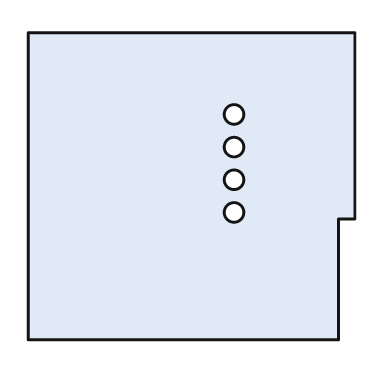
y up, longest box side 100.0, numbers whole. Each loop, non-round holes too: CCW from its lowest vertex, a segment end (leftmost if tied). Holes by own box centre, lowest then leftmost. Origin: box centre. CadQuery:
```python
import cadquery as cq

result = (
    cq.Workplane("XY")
    .moveTo(-50.0, -47.0)
    .lineTo(45.0, -47.0)
    .lineTo(45.0, -10.0)
    .lineTo(50.0, -10.0)
    .lineTo(50.0, 47.0)
    .lineTo(-50.0, 47.0)
    .close()
    .moveTo(13.0, -8.0)
    .circle(3.0)
    .moveTo(13.0, 2.0)
    .circle(3.0)
    .moveTo(13.0, 12.0)
    .circle(3.0)
    .moveTo(13.0, 22.0)
    .circle(3.0)
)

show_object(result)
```